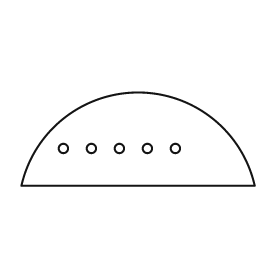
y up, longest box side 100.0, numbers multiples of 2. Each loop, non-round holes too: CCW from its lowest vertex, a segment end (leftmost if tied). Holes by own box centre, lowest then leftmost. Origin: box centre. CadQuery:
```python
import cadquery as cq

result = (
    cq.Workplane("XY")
    .moveTo(-50.0, -20.0)
    .lineTo(50.0, -20.0)
    .threePointArc((0.0, 20.0), (-50.0, -20.0))
    .close()
    .moveTo(-32.0, -4.0)
    .circle(2.0)
    .moveTo(-20.0, -4.0)
    .circle(2.0)
    .moveTo(-8.0, -4.0)
    .circle(2.0)
    .moveTo(4.0, -4.0)
    .circle(2.0)
    .moveTo(16.0, -4.0)
    .circle(2.0)
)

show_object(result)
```